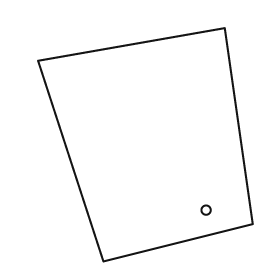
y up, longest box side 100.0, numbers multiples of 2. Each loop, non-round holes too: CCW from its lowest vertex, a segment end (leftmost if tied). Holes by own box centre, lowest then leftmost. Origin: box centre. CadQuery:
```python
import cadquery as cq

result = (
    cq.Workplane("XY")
    .moveTo(-18.0, -50.0)
    .lineTo(46.0, -34.0)
    .lineTo(34.0, 50.0)
    .lineTo(-46.0, 36.0)
    .close()
    .moveTo(26.0, -28.0)
    .circle(2.0)
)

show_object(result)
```